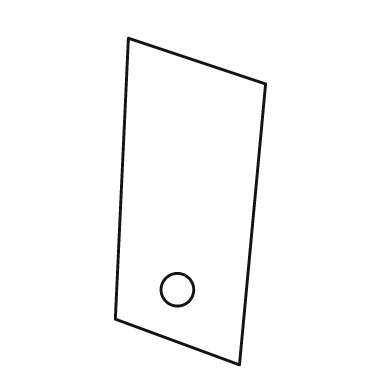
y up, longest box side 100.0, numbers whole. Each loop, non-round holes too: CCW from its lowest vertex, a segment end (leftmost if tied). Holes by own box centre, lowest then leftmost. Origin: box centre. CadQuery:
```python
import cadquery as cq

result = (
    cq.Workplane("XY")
    .moveTo(15.0, -50.0)
    .lineTo(23.0, 36.0)
    .lineTo(-19.0, 50.0)
    .lineTo(-23.0, -36.0)
    .close()
    .moveTo(-4.0, -27.0)
    .circle(5.0)
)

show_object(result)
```